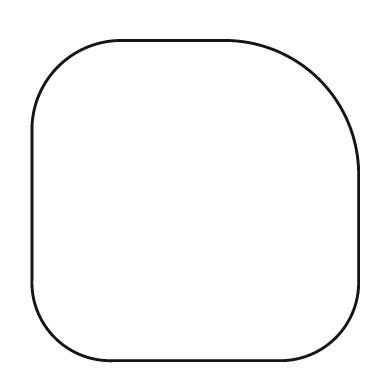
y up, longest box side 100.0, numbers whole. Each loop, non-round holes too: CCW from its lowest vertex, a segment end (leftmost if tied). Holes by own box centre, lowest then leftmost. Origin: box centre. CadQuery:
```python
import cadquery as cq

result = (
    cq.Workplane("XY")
    .moveTo(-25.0, -49.0)
    .lineTo(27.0, -49.0)
    .threePointArc((43.0, -42.0), (50.0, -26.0))
    .lineTo(50.0, 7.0)
    .threePointArc((38.0, 37.0), (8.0, 49.0))
    .lineTo(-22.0, 49.0)
    .threePointArc((-42.0, 41.0), (-50.0, 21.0))
    .lineTo(-50.0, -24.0)
    .threePointArc((-43.0, -42.0), (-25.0, -49.0))
    .close()
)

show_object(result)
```